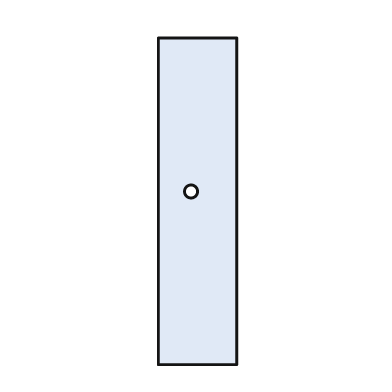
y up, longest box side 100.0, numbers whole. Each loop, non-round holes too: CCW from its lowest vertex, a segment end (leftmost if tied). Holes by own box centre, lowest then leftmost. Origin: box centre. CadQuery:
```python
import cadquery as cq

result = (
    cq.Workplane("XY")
    .moveTo(-12.0, -50.0)
    .lineTo(12.0, -50.0)
    .lineTo(12.0, 50.0)
    .lineTo(-12.0, 50.0)
    .close()
    .moveTo(-2.0, 3.0)
    .circle(2.0)
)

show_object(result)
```